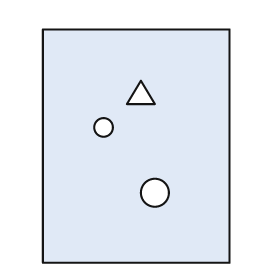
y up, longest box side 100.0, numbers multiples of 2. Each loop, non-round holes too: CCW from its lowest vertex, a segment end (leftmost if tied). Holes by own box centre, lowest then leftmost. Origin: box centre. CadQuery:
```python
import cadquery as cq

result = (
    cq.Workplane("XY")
    .moveTo(-40.0, -50.0)
    .lineTo(40.0, -50.0)
    .lineTo(40.0, 50.0)
    .lineTo(-40.0, 50.0)
    .close()
    .moveTo(8.0, -20.0)
    .circle(6.0)
    .moveTo(-14.0, 8.0)
    .circle(4.0)
    .moveTo(-4.0, 18.0)
    .lineTo(8.0, 18.0)
    .lineTo(2.0, 28.0)
    .close()
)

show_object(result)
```